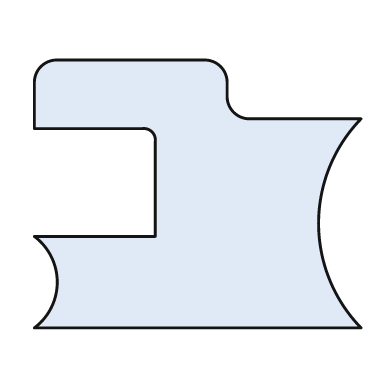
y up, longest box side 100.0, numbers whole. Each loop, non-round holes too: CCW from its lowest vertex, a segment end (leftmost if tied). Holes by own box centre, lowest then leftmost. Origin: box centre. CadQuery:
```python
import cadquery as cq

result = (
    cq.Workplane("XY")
    .moveTo(-50.0, -41.0)
    .lineTo(50.0, -41.0)
    .threePointArc((37.0, -9.0), (50.0, 23.0))
    .lineTo(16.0, 23.0)
    .threePointArc((11.0, 25.0), (9.0, 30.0))
    .lineTo(9.0, 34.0)
    .threePointArc((7.0, 39.0), (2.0, 41.0))
    .lineTo(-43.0, 41.0)
    .threePointArc((-48.0, 39.0), (-50.0, 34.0))
    .lineTo(-50.0, 20.0)
    .lineTo(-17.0, 20.0)
    .threePointArc((-14.0, 19.0), (-13.0, 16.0))
    .lineTo(-13.0, -13.0)
    .lineTo(-50.0, -13.0)
    .threePointArc((-43.0, -27.0), (-50.0, -41.0))
    .close()
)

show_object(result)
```